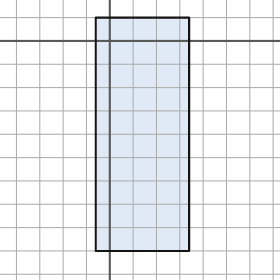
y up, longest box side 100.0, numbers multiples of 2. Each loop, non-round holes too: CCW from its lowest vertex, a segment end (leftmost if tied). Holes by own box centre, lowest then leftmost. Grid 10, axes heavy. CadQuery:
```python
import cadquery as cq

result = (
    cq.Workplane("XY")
    .moveTo(-6.0, -90.0)
    .lineTo(34.0, -90.0)
    .lineTo(34.0, 10.0)
    .lineTo(-6.0, 10.0)
    .close()
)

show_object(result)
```